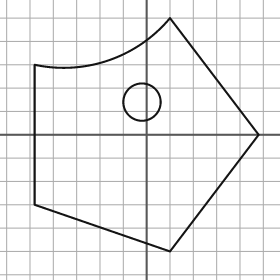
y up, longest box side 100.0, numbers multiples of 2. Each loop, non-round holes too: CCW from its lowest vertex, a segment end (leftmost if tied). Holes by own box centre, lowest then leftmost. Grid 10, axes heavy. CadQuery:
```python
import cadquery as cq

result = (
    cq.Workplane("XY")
    .moveTo(10.0, -50.0)
    .lineTo(48.0, 0.0)
    .lineTo(10.0, 50.0)
    .threePointArc((-16.0, 32.0), (-48.0, 30.0))
    .lineTo(-48.0, -30.0)
    .close()
    .moveTo(-2.0, 14.0)
    .circle(8.0)
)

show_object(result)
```